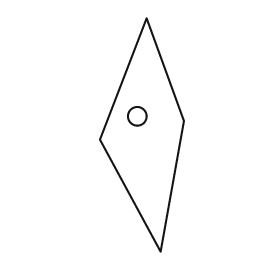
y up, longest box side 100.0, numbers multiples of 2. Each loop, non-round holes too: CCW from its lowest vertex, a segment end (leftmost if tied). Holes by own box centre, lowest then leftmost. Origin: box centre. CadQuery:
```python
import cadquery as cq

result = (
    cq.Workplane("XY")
    .moveTo(8.0, -50.0)
    .lineTo(18.0, 6.0)
    .lineTo(2.0, 50.0)
    .lineTo(-18.0, -2.0)
    .close()
    .moveTo(-2.0, 8.0)
    .circle(4.0)
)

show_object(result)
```